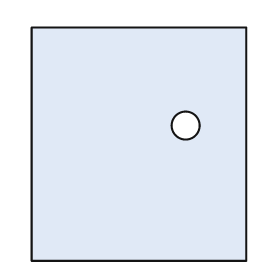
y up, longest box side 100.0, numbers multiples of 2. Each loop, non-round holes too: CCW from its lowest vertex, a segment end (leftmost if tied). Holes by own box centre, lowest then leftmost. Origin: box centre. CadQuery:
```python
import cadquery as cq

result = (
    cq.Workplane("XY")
    .moveTo(-46.0, -50.0)
    .lineTo(46.0, -50.0)
    .lineTo(46.0, 50.0)
    .lineTo(-46.0, 50.0)
    .close()
    .moveTo(20.0, 8.0)
    .circle(6.0)
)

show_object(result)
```